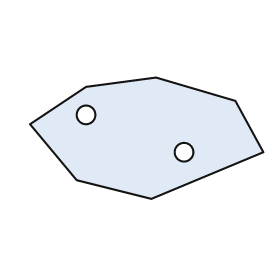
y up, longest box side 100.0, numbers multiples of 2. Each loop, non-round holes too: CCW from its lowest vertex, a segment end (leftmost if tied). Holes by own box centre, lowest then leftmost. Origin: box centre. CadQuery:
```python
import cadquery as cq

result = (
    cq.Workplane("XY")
    .moveTo(2.0, -26.0)
    .lineTo(50.0, -6.0)
    .lineTo(38.0, 16.0)
    .lineTo(4.0, 26.0)
    .lineTo(-26.0, 22.0)
    .lineTo(-50.0, 6.0)
    .lineTo(-30.0, -18.0)
    .close()
    .moveTo(16.0, -6.0)
    .circle(4.0)
    .moveTo(-26.0, 10.0)
    .circle(4.0)
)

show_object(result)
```